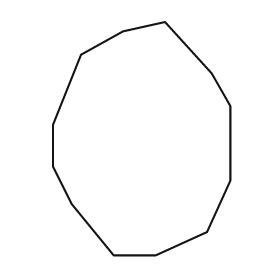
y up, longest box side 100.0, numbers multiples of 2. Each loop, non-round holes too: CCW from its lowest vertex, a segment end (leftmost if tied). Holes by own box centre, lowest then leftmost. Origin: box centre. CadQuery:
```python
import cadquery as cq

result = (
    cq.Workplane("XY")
    .moveTo(-12.0, -50.0)
    .lineTo(6.0, -50.0)
    .lineTo(28.0, -40.0)
    .lineTo(38.0, -18.0)
    .lineTo(38.0, 14.0)
    .lineTo(30.0, 28.0)
    .lineTo(10.0, 50.0)
    .lineTo(-8.0, 46.0)
    .lineTo(-26.0, 36.0)
    .lineTo(-38.0, 6.0)
    .lineTo(-38.0, -12.0)
    .lineTo(-30.0, -28.0)
    .close()
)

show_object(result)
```